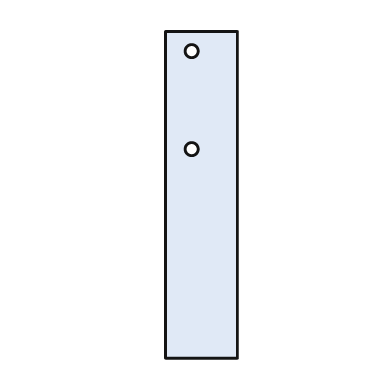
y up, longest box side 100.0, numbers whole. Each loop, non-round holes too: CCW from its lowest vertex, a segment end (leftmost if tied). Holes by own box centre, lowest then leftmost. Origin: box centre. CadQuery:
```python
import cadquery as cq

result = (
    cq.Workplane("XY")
    .moveTo(-11.0, -50.0)
    .lineTo(11.0, -50.0)
    .lineTo(11.0, 50.0)
    .lineTo(-11.0, 50.0)
    .close()
    .moveTo(-3.0, 14.0)
    .circle(2.0)
    .moveTo(-3.0, 44.0)
    .circle(2.0)
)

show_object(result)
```